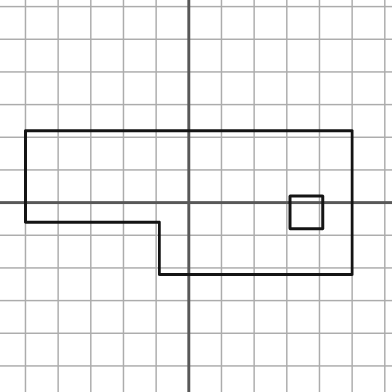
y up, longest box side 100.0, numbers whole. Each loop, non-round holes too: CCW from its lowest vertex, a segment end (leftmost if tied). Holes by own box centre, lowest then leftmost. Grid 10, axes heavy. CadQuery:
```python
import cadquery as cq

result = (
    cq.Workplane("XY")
    .moveTo(-9.0, -22.0)
    .lineTo(50.0, -22.0)
    .lineTo(50.0, 22.0)
    .lineTo(-50.0, 22.0)
    .lineTo(-50.0, -6.0)
    .lineTo(-9.0, -6.0)
    .close()
    .moveTo(31.0, -8.0)
    .lineTo(41.0, -8.0)
    .lineTo(41.0, 2.0)
    .lineTo(31.0, 2.0)
    .close()
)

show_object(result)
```